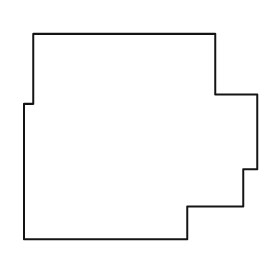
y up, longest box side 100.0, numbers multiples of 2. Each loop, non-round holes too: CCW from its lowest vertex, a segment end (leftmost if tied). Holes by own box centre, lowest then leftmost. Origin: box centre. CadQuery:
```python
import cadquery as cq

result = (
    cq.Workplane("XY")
    .moveTo(-50.0, -44.0)
    .lineTo(20.0, -44.0)
    .lineTo(20.0, -30.0)
    .lineTo(44.0, -30.0)
    .lineTo(44.0, -14.0)
    .lineTo(50.0, -14.0)
    .lineTo(50.0, 18.0)
    .lineTo(32.0, 18.0)
    .lineTo(32.0, 44.0)
    .lineTo(-46.0, 44.0)
    .lineTo(-46.0, 14.0)
    .lineTo(-50.0, 14.0)
    .close()
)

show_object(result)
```